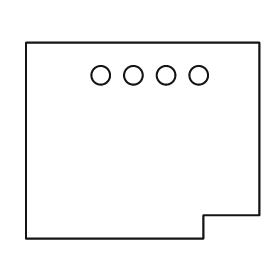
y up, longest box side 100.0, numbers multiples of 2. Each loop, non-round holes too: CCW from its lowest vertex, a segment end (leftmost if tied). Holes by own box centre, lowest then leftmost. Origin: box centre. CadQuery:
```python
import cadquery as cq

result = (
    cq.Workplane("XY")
    .moveTo(-50.0, -42.0)
    .lineTo(26.0, -42.0)
    .lineTo(26.0, -32.0)
    .lineTo(50.0, -32.0)
    .lineTo(50.0, 42.0)
    .lineTo(-50.0, 42.0)
    .close()
    .moveTo(-18.0, 28.0)
    .circle(4.0)
    .moveTo(-4.0, 28.0)
    .circle(4.0)
    .moveTo(10.0, 28.0)
    .circle(4.0)
    .moveTo(24.0, 28.0)
    .circle(4.0)
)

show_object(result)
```